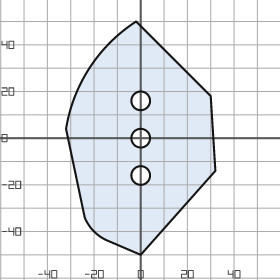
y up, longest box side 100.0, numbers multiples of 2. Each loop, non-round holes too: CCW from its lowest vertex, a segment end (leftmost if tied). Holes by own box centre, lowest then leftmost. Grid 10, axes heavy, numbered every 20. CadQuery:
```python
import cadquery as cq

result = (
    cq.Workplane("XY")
    .moveTo(0.0, -50.0)
    .lineTo(32.0, -14.0)
    .lineTo(30.0, 18.0)
    .lineTo(-2.0, 50.0)
    .threePointArc((-22.0, 30.0), (-32.0, 4.0))
    .lineTo(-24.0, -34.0)
    .threePointArc((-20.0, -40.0), (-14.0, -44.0))
    .close()
    .moveTo(0.0, -16.0)
    .circle(4.0)
    .moveTo(0.0, 0.0)
    .circle(4.0)
    .moveTo(0.0, 16.0)
    .circle(4.0)
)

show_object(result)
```